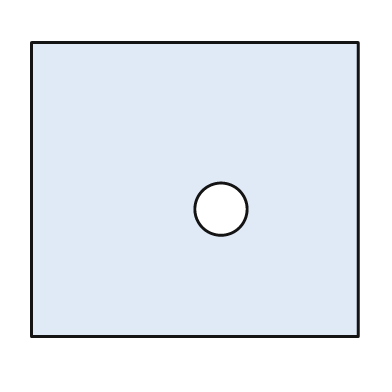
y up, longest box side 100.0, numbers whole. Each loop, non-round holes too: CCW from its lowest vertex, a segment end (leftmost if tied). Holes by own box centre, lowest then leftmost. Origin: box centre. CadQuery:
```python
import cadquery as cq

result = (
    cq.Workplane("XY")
    .moveTo(-50.0, -45.0)
    .lineTo(50.0, -45.0)
    .lineTo(50.0, 45.0)
    .lineTo(-50.0, 45.0)
    .close()
    .moveTo(8.0, -6.0)
    .circle(8.0)
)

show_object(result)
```